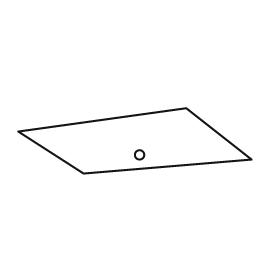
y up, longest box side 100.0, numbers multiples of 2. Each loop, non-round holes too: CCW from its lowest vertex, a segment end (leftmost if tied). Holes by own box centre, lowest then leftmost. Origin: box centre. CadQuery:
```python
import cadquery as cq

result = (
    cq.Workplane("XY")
    .moveTo(-22.0, -14.0)
    .lineTo(50.0, -8.0)
    .lineTo(22.0, 14.0)
    .lineTo(-50.0, 4.0)
    .close()
    .moveTo(2.0, -6.0)
    .circle(2.0)
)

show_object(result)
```